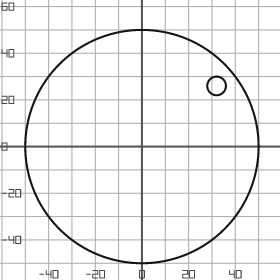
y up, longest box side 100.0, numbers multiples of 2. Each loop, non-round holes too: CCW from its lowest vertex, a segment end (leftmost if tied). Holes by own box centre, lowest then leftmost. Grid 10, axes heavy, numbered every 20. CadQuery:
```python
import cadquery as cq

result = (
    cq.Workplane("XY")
    .moveTo(0.0, 0.0)
    .circle(50.0)
    .moveTo(32.0, 26.0)
    .circle(4.0)
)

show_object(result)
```